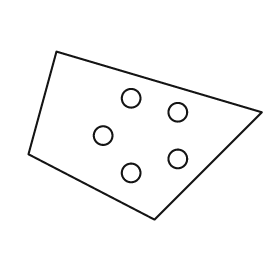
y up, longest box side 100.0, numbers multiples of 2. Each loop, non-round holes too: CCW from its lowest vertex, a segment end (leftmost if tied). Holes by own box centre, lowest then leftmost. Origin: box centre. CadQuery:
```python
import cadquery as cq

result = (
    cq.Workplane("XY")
    .moveTo(4.0, -36.0)
    .lineTo(50.0, 10.0)
    .lineTo(-38.0, 36.0)
    .lineTo(-50.0, -8.0)
    .close()
    .moveTo(-6.0, -16.0)
    .circle(4.0)
    .moveTo(14.0, -10.0)
    .circle(4.0)
    .moveTo(-18.0, 0.0)
    .circle(4.0)
    .moveTo(14.0, 10.0)
    .circle(4.0)
    .moveTo(-6.0, 16.0)
    .circle(4.0)
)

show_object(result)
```